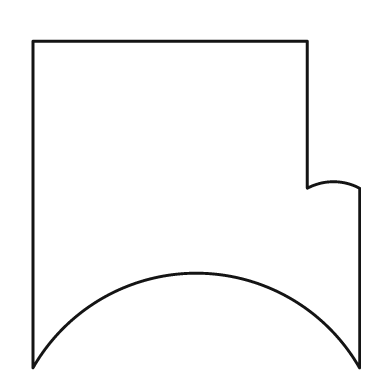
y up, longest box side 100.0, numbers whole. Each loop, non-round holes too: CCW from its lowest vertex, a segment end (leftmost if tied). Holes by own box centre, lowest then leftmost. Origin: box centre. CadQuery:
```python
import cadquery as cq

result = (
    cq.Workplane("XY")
    .moveTo(-50.0, -50.0)
    .threePointArc((0.0, -21.0), (50.0, -50.0))
    .lineTo(50.0, 5.0)
    .threePointArc((42.0, 7.0), (34.0, 5.0))
    .lineTo(34.0, 50.0)
    .lineTo(-50.0, 50.0)
    .close()
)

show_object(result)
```